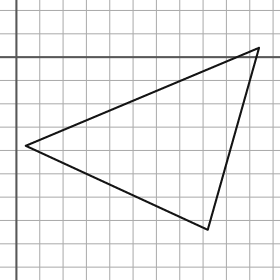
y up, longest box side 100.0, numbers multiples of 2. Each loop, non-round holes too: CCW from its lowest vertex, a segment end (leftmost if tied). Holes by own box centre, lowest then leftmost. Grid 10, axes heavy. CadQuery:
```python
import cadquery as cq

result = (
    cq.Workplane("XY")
    .moveTo(82.0, -74.0)
    .lineTo(104.0, 4.0)
    .lineTo(4.0, -38.0)
    .close()
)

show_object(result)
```